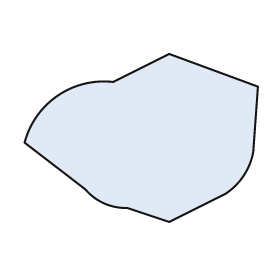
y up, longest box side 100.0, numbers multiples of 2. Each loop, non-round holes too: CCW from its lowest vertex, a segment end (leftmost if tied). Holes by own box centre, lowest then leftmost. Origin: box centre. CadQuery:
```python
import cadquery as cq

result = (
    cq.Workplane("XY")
    .moveTo(12.0, -36.0)
    .lineTo(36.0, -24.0)
    .threePointArc((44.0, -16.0), (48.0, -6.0))
    .lineTo(50.0, 22.0)
    .lineTo(12.0, 36.0)
    .lineTo(-12.0, 24.0)
    .threePointArc((-36.0, 18.0), (-50.0, -2.0))
    .lineTo(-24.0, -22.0)
    .threePointArc((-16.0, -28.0), (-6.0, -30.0))
    .close()
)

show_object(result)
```